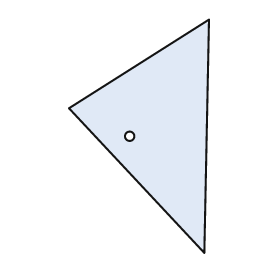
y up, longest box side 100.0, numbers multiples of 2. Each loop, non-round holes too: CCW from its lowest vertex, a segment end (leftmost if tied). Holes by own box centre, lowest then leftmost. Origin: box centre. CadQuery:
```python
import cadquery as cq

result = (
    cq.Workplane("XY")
    .moveTo(28.0, -50.0)
    .lineTo(30.0, 50.0)
    .lineTo(-30.0, 12.0)
    .close()
    .moveTo(-4.0, 0.0)
    .circle(2.0)
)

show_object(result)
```